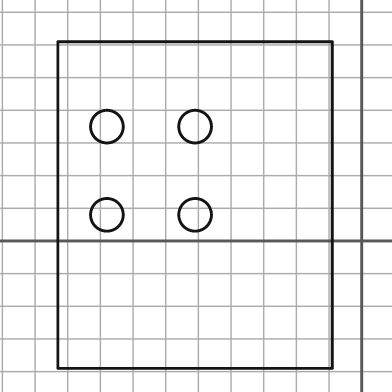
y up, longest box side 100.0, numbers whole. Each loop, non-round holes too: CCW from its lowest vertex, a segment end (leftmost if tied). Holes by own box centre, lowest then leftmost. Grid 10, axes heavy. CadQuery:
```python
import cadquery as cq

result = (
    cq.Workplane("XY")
    .moveTo(-93.0, -39.0)
    .lineTo(-9.0, -39.0)
    .lineTo(-9.0, 61.0)
    .lineTo(-93.0, 61.0)
    .close()
    .moveTo(-78.0, 8.0)
    .circle(5.0)
    .moveTo(-51.0, 8.0)
    .circle(5.0)
    .moveTo(-78.0, 35.0)
    .circle(5.0)
    .moveTo(-51.0, 35.0)
    .circle(5.0)
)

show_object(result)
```